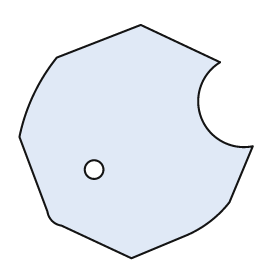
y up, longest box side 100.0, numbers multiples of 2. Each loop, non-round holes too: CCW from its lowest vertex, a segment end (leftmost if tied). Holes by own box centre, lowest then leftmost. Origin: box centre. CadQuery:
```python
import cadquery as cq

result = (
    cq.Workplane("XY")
    .moveTo(-2.0, -50.0)
    .lineTo(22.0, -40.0)
    .threePointArc((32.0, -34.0), (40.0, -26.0))
    .lineTo(50.0, -2.0)
    .threePointArc((28.0, 10.0), (36.0, 34.0))
    .lineTo(2.0, 50.0)
    .lineTo(-34.0, 36.0)
    .threePointArc((-44.0, 20.0), (-50.0, 2.0))
    .lineTo(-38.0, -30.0)
    .threePointArc((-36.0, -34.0), (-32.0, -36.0))
    .close()
    .moveTo(-18.0, -12.0)
    .circle(4.0)
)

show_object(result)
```